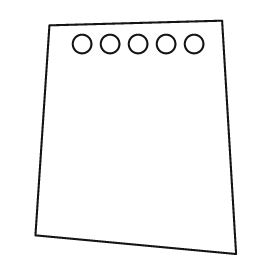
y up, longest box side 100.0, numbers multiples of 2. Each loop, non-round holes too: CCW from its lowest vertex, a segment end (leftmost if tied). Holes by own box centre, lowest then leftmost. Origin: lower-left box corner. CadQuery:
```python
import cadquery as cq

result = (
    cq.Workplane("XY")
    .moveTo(86.0, 0.0)
    .lineTo(80.0, 100.0)
    .lineTo(6.0, 98.0)
    .lineTo(0.0, 8.0)
    .close()
    .moveTo(20.0, 90.0)
    .circle(4.0)
    .moveTo(32.0, 90.0)
    .circle(4.0)
    .moveTo(44.0, 90.0)
    .circle(4.0)
    .moveTo(56.0, 90.0)
    .circle(4.0)
    .moveTo(68.0, 90.0)
    .circle(4.0)
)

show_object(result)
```